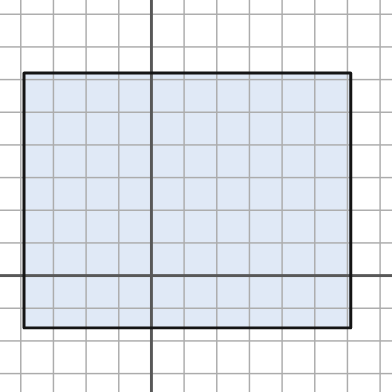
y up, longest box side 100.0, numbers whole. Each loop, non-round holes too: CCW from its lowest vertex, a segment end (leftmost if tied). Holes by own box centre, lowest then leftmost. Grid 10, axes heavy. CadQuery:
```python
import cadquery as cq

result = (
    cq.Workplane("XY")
    .moveTo(-39.0, -16.0)
    .lineTo(61.0, -16.0)
    .lineTo(61.0, 62.0)
    .lineTo(-39.0, 62.0)
    .close()
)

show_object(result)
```